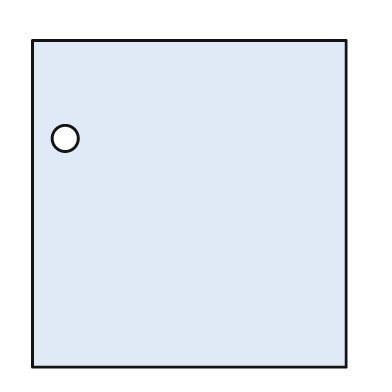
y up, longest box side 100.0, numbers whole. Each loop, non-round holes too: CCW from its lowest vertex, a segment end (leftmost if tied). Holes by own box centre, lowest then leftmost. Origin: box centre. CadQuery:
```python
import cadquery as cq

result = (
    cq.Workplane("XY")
    .moveTo(-48.0, -50.0)
    .lineTo(48.0, -50.0)
    .lineTo(48.0, 50.0)
    .lineTo(-48.0, 50.0)
    .close()
    .moveTo(-38.0, 20.0)
    .circle(4.0)
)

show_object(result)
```